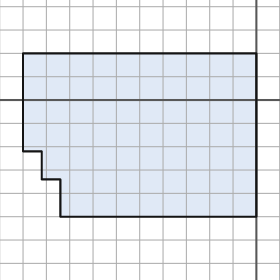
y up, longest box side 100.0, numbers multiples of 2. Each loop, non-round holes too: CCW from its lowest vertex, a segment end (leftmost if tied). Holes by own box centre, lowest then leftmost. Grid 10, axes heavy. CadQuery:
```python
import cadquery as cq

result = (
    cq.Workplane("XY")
    .moveTo(-84.0, -50.0)
    .lineTo(0.0, -50.0)
    .lineTo(0.0, 20.0)
    .lineTo(-100.0, 20.0)
    .lineTo(-100.0, -22.0)
    .lineTo(-92.0, -22.0)
    .lineTo(-92.0, -34.0)
    .lineTo(-84.0, -34.0)
    .close()
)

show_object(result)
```